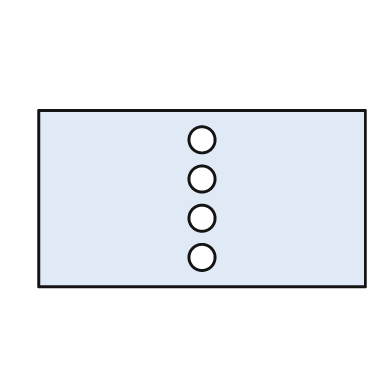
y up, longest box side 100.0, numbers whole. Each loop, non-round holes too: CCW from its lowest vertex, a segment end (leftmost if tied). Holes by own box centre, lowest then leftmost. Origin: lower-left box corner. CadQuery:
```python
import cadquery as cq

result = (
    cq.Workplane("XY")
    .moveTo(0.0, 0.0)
    .lineTo(100.0, 0.0)
    .lineTo(100.0, 54.0)
    .lineTo(0.0, 54.0)
    .close()
    .moveTo(50.0, 9.0)
    .circle(4.0)
    .moveTo(50.0, 21.0)
    .circle(4.0)
    .moveTo(50.0, 33.0)
    .circle(4.0)
    .moveTo(50.0, 45.0)
    .circle(4.0)
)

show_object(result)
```